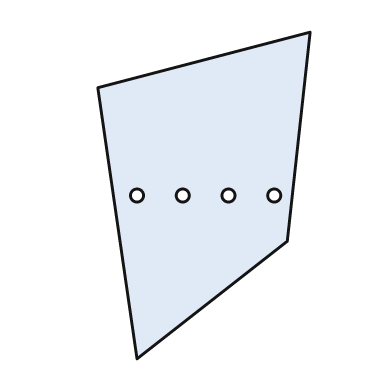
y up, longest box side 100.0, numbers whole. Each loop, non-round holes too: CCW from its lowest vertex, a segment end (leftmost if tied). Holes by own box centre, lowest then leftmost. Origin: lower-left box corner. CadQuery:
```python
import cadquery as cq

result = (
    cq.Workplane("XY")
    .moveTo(12.0, 0.0)
    .lineTo(58.0, 36.0)
    .lineTo(65.0, 100.0)
    .lineTo(0.0, 83.0)
    .close()
    .moveTo(12.0, 50.0)
    .circle(2.0)
    .moveTo(26.0, 50.0)
    .circle(2.0)
    .moveTo(40.0, 50.0)
    .circle(2.0)
    .moveTo(54.0, 50.0)
    .circle(2.0)
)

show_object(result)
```